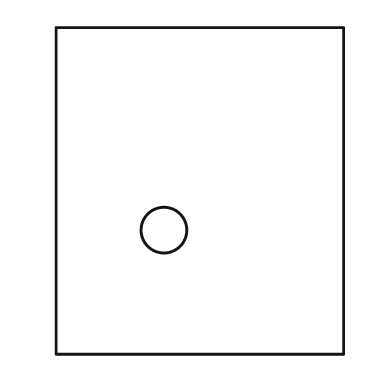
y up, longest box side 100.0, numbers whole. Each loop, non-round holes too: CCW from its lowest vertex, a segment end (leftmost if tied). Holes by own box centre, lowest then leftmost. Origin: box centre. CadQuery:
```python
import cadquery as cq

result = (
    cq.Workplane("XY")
    .moveTo(-44.0, -50.0)
    .lineTo(44.0, -50.0)
    .lineTo(44.0, 50.0)
    .lineTo(-44.0, 50.0)
    .close()
    .moveTo(-11.0, -12.0)
    .circle(7.0)
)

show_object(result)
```